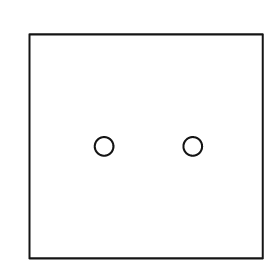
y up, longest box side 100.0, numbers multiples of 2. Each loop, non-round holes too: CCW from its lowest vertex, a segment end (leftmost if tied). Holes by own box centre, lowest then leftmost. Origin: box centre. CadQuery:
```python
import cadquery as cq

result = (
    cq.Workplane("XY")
    .moveTo(-50.0, -48.0)
    .lineTo(50.0, -48.0)
    .lineTo(50.0, 48.0)
    .lineTo(-50.0, 48.0)
    .close()
    .moveTo(-18.0, 0.0)
    .circle(4.0)
    .moveTo(20.0, 0.0)
    .circle(4.0)
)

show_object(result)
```